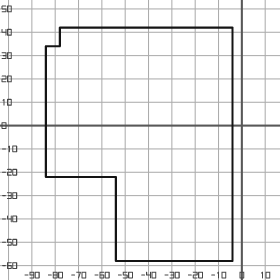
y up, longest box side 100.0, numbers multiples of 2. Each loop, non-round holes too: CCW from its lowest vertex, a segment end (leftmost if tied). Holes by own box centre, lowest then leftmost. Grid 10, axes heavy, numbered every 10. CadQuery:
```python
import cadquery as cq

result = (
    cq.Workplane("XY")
    .moveTo(-54.0, -58.0)
    .lineTo(-4.0, -58.0)
    .lineTo(-4.0, 42.0)
    .lineTo(-78.0, 42.0)
    .lineTo(-78.0, 34.0)
    .lineTo(-84.0, 34.0)
    .lineTo(-84.0, -22.0)
    .lineTo(-54.0, -22.0)
    .close()
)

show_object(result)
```